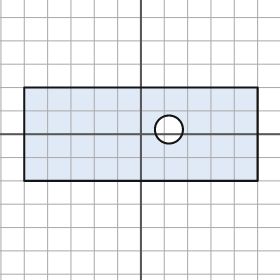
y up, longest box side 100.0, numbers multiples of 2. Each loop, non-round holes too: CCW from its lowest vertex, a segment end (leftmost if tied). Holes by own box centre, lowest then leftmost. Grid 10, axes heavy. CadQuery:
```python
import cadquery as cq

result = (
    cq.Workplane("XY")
    .moveTo(-50.0, -20.0)
    .lineTo(50.0, -20.0)
    .lineTo(50.0, 20.0)
    .lineTo(-50.0, 20.0)
    .close()
    .moveTo(12.0, 2.0)
    .circle(6.0)
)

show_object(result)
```